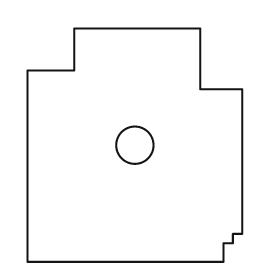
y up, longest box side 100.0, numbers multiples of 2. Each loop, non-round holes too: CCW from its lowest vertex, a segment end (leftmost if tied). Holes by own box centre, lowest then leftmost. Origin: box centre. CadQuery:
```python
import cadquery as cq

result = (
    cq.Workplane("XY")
    .moveTo(-46.0, -50.0)
    .lineTo(38.0, -50.0)
    .lineTo(38.0, -42.0)
    .lineTo(42.0, -42.0)
    .lineTo(42.0, -38.0)
    .lineTo(46.0, -38.0)
    .lineTo(46.0, 24.0)
    .lineTo(28.0, 24.0)
    .lineTo(28.0, 50.0)
    .lineTo(-26.0, 50.0)
    .lineTo(-26.0, 32.0)
    .lineTo(-46.0, 32.0)
    .close()
    .moveTo(0.0, 0.0)
    .circle(8.0)
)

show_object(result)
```